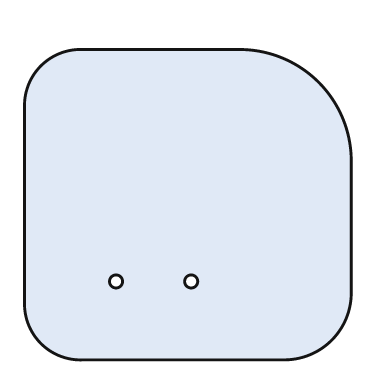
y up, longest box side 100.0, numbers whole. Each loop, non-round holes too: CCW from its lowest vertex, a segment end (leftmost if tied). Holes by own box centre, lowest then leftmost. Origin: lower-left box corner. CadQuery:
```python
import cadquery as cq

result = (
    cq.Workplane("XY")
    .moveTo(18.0, 0.0)
    .lineTo(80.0, 0.0)
    .threePointArc((94.0, 6.0), (100.0, 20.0))
    .lineTo(100.0, 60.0)
    .threePointArc((90.0, 85.0), (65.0, 95.0))
    .lineTo(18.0, 95.0)
    .threePointArc((5.0, 90.0), (0.0, 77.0))
    .lineTo(0.0, 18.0)
    .threePointArc((5.0, 5.0), (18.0, 0.0))
    .close()
    .moveTo(28.0, 24.0)
    .circle(2.0)
    .moveTo(51.0, 24.0)
    .circle(2.0)
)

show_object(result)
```